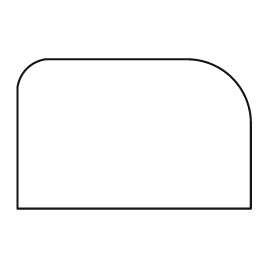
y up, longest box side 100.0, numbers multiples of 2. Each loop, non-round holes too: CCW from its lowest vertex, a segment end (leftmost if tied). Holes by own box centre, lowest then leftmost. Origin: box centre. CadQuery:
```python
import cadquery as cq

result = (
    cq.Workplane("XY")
    .moveTo(-50.0, -32.0)
    .lineTo(50.0, -32.0)
    .lineTo(50.0, 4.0)
    .threePointArc((42.0, 24.0), (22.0, 32.0))
    .lineTo(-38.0, 32.0)
    .threePointArc((-46.0, 28.0), (-50.0, 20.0))
    .close()
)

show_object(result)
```